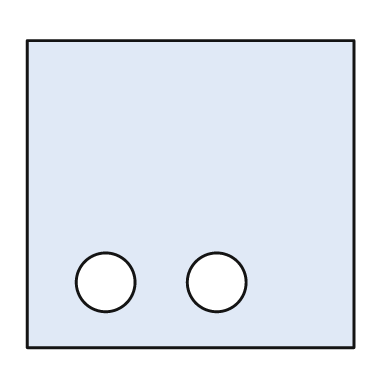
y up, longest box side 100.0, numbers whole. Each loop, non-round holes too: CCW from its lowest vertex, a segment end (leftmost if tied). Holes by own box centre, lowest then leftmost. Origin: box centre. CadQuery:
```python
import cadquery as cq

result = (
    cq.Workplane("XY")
    .moveTo(-50.0, -47.0)
    .lineTo(50.0, -47.0)
    .lineTo(50.0, 47.0)
    .lineTo(-50.0, 47.0)
    .close()
    .moveTo(-26.0, -27.0)
    .circle(9.0)
    .moveTo(8.0, -27.0)
    .circle(9.0)
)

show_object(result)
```